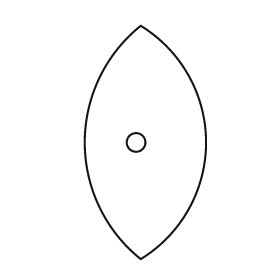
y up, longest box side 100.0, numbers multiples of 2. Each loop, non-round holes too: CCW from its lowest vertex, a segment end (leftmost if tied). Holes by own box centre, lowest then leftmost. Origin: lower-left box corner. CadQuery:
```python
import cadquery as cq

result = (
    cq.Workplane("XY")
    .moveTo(24.0, 0.0)
    .threePointArc((52.0, 50.0), (24.0, 100.0))
    .threePointArc((0.0, 50.0), (24.0, 0.0))
    .close()
    .moveTo(22.0, 50.0)
    .circle(4.0)
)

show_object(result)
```